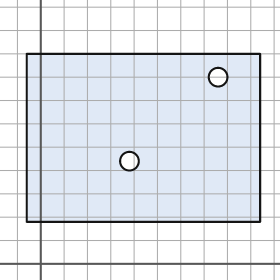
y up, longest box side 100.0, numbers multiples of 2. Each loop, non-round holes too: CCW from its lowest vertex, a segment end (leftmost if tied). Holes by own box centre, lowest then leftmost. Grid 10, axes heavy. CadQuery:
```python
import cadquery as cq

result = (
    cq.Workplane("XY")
    .moveTo(-6.0, 18.0)
    .lineTo(94.0, 18.0)
    .lineTo(94.0, 90.0)
    .lineTo(-6.0, 90.0)
    .close()
    .moveTo(38.0, 44.0)
    .circle(4.0)
    .moveTo(76.0, 80.0)
    .circle(4.0)
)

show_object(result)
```